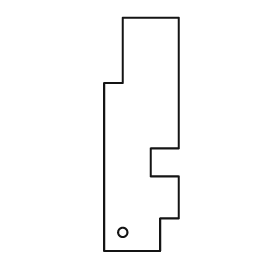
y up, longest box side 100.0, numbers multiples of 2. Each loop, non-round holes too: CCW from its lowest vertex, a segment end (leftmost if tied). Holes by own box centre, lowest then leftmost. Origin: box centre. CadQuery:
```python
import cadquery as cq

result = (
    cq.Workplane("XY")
    .moveTo(-16.0, -50.0)
    .lineTo(8.0, -50.0)
    .lineTo(8.0, -36.0)
    .lineTo(16.0, -36.0)
    .lineTo(16.0, -18.0)
    .lineTo(4.0, -18.0)
    .lineTo(4.0, -6.0)
    .lineTo(16.0, -6.0)
    .lineTo(16.0, 50.0)
    .lineTo(-8.0, 50.0)
    .lineTo(-8.0, 22.0)
    .lineTo(-16.0, 22.0)
    .close()
    .moveTo(-8.0, -42.0)
    .circle(2.0)
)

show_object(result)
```